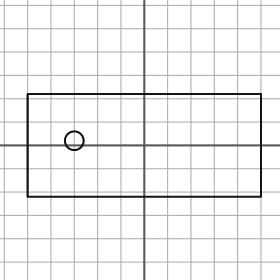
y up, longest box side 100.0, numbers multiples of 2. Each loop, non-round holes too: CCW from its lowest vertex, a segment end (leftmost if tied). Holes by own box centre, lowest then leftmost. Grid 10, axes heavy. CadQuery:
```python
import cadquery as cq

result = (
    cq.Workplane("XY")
    .moveTo(-50.0, -22.0)
    .lineTo(50.0, -22.0)
    .lineTo(50.0, 22.0)
    .lineTo(-50.0, 22.0)
    .close()
    .moveTo(-30.0, 2.0)
    .circle(4.0)
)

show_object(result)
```